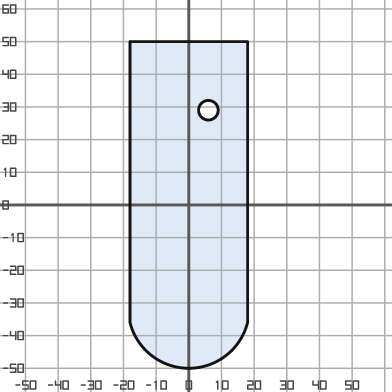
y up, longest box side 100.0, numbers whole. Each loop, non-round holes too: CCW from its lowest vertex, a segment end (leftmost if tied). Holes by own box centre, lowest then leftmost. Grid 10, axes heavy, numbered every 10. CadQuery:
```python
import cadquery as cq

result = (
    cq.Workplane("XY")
    .moveTo(-18.0, -36.0)
    .threePointArc((0.0, -50.0), (18.0, -36.0))
    .lineTo(18.0, 50.0)
    .lineTo(-18.0, 50.0)
    .close()
    .moveTo(6.0, 29.0)
    .circle(3.0)
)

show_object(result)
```